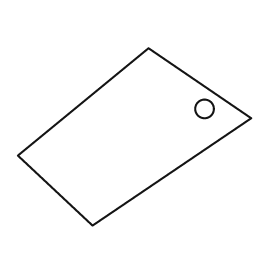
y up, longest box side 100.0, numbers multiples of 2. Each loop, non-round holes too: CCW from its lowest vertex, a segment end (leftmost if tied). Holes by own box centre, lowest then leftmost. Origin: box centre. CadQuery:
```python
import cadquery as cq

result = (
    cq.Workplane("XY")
    .moveTo(-18.0, -38.0)
    .lineTo(50.0, 8.0)
    .lineTo(6.0, 38.0)
    .lineTo(-50.0, -8.0)
    .close()
    .moveTo(30.0, 12.0)
    .circle(4.0)
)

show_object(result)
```